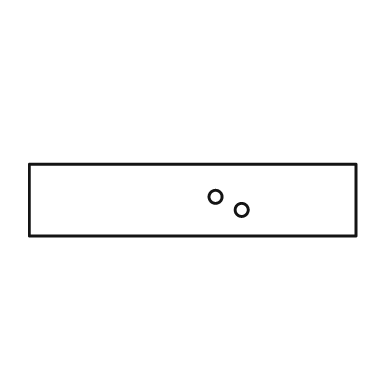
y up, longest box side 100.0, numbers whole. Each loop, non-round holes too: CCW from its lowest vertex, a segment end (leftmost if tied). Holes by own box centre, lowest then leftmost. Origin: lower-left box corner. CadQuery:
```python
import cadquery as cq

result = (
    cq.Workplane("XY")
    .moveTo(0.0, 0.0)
    .lineTo(100.0, 0.0)
    .lineTo(100.0, 22.0)
    .lineTo(0.0, 22.0)
    .close()
    .moveTo(65.0, 8.0)
    .circle(2.0)
    .moveTo(57.0, 12.0)
    .circle(2.0)
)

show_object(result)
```